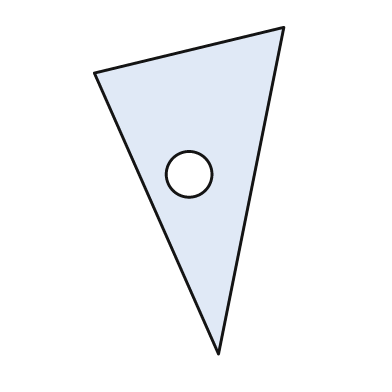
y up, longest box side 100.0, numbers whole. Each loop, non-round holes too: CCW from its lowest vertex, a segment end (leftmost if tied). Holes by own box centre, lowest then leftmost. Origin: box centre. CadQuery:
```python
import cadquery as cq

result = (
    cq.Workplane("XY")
    .moveTo(9.0, -50.0)
    .lineTo(29.0, 50.0)
    .lineTo(-29.0, 36.0)
    .close()
    .moveTo(0.0, 5.0)
    .circle(7.0)
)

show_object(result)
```